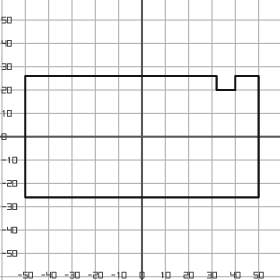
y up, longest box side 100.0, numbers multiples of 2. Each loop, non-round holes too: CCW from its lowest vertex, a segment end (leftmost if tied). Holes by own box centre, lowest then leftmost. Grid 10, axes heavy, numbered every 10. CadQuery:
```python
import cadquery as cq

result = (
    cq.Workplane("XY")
    .moveTo(-50.0, -26.0)
    .lineTo(50.0, -26.0)
    .lineTo(50.0, 26.0)
    .lineTo(40.0, 26.0)
    .lineTo(40.0, 20.0)
    .lineTo(32.0, 20.0)
    .lineTo(32.0, 26.0)
    .lineTo(-50.0, 26.0)
    .close()
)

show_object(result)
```